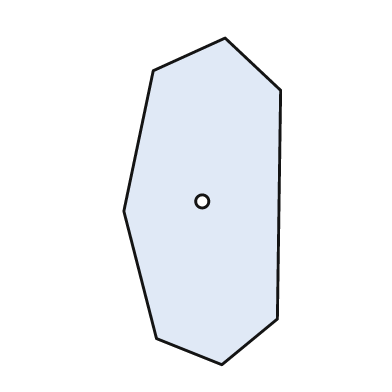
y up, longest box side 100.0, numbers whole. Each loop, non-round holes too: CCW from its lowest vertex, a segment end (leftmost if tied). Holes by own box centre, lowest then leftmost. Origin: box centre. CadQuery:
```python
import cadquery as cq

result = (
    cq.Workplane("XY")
    .moveTo(6.0, -50.0)
    .lineTo(23.0, -36.0)
    .lineTo(24.0, 34.0)
    .lineTo(7.0, 50.0)
    .lineTo(-15.0, 40.0)
    .lineTo(-24.0, -3.0)
    .lineTo(-14.0, -42.0)
    .close()
    .moveTo(0.0, 0.0)
    .circle(2.0)
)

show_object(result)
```